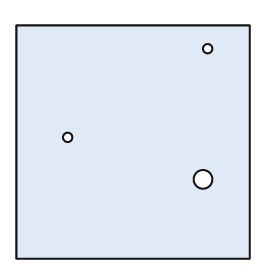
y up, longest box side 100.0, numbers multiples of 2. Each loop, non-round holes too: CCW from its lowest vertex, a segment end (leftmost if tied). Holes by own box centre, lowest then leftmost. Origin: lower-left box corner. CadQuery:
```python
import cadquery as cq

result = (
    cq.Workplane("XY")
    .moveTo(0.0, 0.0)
    .lineTo(100.0, 0.0)
    .lineTo(100.0, 100.0)
    .lineTo(0.0, 100.0)
    .close()
    .moveTo(80.0, 34.0)
    .circle(4.0)
    .moveTo(22.0, 52.0)
    .circle(2.0)
    .moveTo(82.0, 90.0)
    .circle(2.0)
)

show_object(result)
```